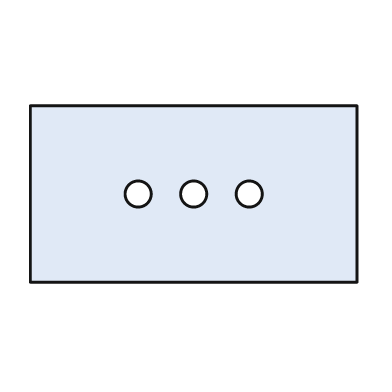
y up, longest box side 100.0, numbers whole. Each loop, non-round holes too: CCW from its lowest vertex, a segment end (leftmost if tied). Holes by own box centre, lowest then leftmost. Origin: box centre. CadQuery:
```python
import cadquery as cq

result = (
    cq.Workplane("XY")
    .moveTo(-50.0, -27.0)
    .lineTo(50.0, -27.0)
    .lineTo(50.0, 27.0)
    .lineTo(-50.0, 27.0)
    .close()
    .moveTo(-17.0, 0.0)
    .circle(4.0)
    .moveTo(0.0, 0.0)
    .circle(4.0)
    .moveTo(17.0, 0.0)
    .circle(4.0)
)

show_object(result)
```